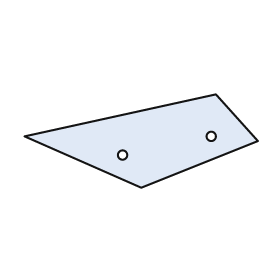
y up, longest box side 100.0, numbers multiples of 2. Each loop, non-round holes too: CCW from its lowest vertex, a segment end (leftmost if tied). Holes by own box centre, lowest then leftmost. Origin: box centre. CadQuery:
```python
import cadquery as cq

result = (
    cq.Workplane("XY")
    .moveTo(0.0, -20.0)
    .lineTo(50.0, 0.0)
    .lineTo(32.0, 20.0)
    .lineTo(-50.0, 2.0)
    .close()
    .moveTo(-8.0, -6.0)
    .circle(2.0)
    .moveTo(30.0, 2.0)
    .circle(2.0)
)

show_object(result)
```